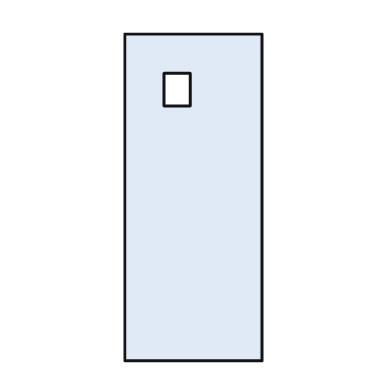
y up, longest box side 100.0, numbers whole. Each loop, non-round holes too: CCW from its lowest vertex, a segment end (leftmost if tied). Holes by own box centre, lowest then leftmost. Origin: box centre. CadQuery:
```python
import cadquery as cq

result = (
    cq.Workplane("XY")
    .moveTo(-21.0, -50.0)
    .lineTo(21.0, -50.0)
    .lineTo(21.0, 50.0)
    .lineTo(-21.0, 50.0)
    .close()
    .moveTo(-9.0, 28.0)
    .lineTo(-1.0, 28.0)
    .lineTo(-1.0, 38.0)
    .lineTo(-9.0, 38.0)
    .close()
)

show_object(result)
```